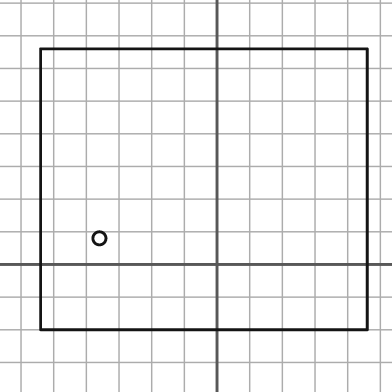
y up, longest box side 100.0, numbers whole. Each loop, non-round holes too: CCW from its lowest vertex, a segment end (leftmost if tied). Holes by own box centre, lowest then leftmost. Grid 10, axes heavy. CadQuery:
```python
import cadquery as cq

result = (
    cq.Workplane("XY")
    .moveTo(-54.0, -20.0)
    .lineTo(46.0, -20.0)
    .lineTo(46.0, 66.0)
    .lineTo(-54.0, 66.0)
    .close()
    .moveTo(-36.0, 8.0)
    .circle(2.0)
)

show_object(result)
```